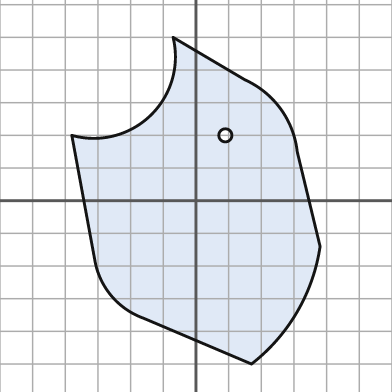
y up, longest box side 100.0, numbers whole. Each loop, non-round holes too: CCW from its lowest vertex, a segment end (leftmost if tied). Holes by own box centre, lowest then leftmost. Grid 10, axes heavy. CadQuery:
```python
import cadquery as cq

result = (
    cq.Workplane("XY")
    .moveTo(17.0, -50.0)
    .threePointArc((31.0, -34.0), (38.0, -14.0))
    .lineTo(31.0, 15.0)
    .threePointArc((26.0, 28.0), (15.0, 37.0))
    .lineTo(-7.0, 50.0)
    .threePointArc((-14.0, 26.0), (-38.0, 20.0))
    .lineTo(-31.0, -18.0)
    .threePointArc((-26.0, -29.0), (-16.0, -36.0))
    .close()
    .moveTo(9.0, 20.0)
    .circle(2.0)
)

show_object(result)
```